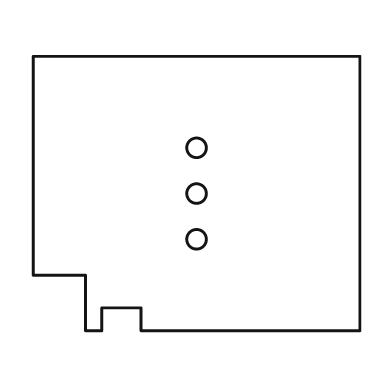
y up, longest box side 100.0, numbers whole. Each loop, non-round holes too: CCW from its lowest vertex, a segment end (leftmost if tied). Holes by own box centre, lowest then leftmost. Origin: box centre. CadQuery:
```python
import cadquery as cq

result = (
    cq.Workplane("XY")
    .moveTo(-34.0, -42.0)
    .lineTo(-29.0, -42.0)
    .lineTo(-29.0, -35.0)
    .lineTo(-17.0, -35.0)
    .lineTo(-17.0, -42.0)
    .lineTo(50.0, -42.0)
    .lineTo(50.0, 42.0)
    .lineTo(-50.0, 42.0)
    .lineTo(-50.0, -25.0)
    .lineTo(-34.0, -25.0)
    .close()
    .moveTo(0.0, -14.0)
    .circle(3.0)
    .moveTo(0.0, 0.0)
    .circle(3.0)
    .moveTo(0.0, 14.0)
    .circle(3.0)
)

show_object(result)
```